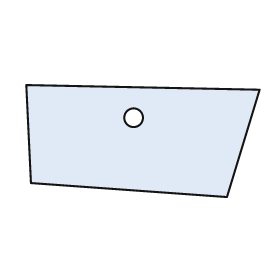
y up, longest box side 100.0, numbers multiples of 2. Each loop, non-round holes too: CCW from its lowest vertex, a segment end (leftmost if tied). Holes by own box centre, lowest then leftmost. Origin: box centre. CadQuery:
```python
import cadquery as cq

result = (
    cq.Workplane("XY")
    .moveTo(36.0, -24.0)
    .lineTo(50.0, 22.0)
    .lineTo(-50.0, 24.0)
    .lineTo(-48.0, -18.0)
    .close()
    .moveTo(-4.0, 10.0)
    .circle(4.0)
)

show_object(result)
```